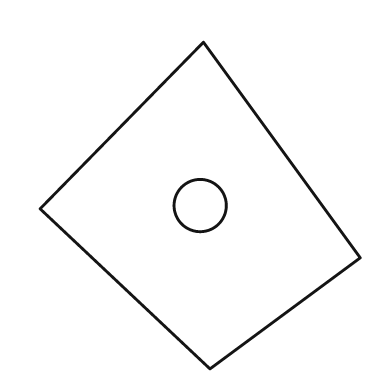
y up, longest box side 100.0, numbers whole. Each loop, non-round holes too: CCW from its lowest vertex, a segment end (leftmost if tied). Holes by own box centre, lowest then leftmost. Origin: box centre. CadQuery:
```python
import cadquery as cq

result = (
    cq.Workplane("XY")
    .moveTo(3.0, -50.0)
    .lineTo(49.0, -16.0)
    .lineTo(1.0, 50.0)
    .lineTo(-49.0, -1.0)
    .close()
    .moveTo(0.0, 0.0)
    .circle(8.0)
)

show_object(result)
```